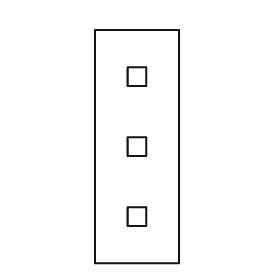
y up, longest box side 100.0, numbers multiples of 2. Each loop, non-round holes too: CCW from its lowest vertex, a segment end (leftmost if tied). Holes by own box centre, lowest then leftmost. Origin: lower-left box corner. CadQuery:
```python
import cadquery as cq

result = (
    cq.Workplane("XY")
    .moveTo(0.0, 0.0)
    .lineTo(36.0, 0.0)
    .lineTo(36.0, 100.0)
    .lineTo(0.0, 100.0)
    .close()
    .moveTo(14.0, 16.0)
    .lineTo(22.0, 16.0)
    .lineTo(22.0, 24.0)
    .lineTo(14.0, 24.0)
    .close()
    .moveTo(14.0, 46.0)
    .lineTo(22.0, 46.0)
    .lineTo(22.0, 54.0)
    .lineTo(14.0, 54.0)
    .close()
    .moveTo(14.0, 76.0)
    .lineTo(22.0, 76.0)
    .lineTo(22.0, 84.0)
    .lineTo(14.0, 84.0)
    .close()
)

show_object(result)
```